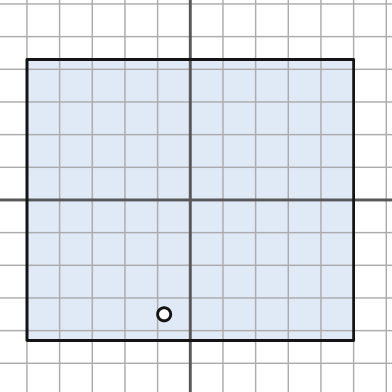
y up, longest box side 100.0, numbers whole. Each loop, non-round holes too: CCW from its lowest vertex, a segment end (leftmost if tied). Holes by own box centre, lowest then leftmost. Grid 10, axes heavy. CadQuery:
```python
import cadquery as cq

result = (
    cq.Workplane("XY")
    .moveTo(-50.0, -43.0)
    .lineTo(50.0, -43.0)
    .lineTo(50.0, 43.0)
    .lineTo(-50.0, 43.0)
    .close()
    .moveTo(-8.0, -35.0)
    .circle(2.0)
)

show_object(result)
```